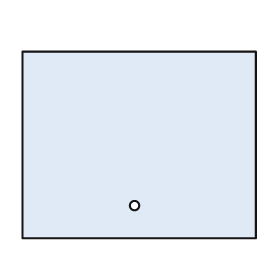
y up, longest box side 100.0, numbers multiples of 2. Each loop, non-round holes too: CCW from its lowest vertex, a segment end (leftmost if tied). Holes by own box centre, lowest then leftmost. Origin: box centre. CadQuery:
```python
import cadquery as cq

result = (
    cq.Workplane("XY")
    .moveTo(-50.0, -40.0)
    .lineTo(50.0, -40.0)
    .lineTo(50.0, 40.0)
    .lineTo(-50.0, 40.0)
    .close()
    .moveTo(-2.0, -26.0)
    .circle(2.0)
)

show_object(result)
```